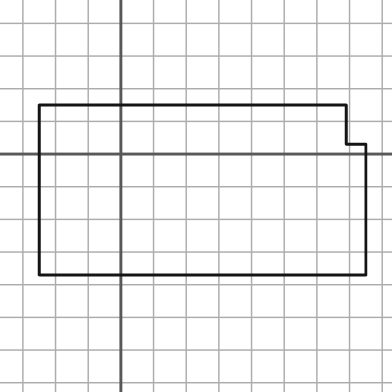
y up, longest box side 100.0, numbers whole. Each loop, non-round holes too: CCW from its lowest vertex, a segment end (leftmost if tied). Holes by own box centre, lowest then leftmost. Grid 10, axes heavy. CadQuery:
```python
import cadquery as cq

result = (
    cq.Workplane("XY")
    .moveTo(-25.0, -37.0)
    .lineTo(75.0, -37.0)
    .lineTo(75.0, 3.0)
    .lineTo(69.0, 3.0)
    .lineTo(69.0, 15.0)
    .lineTo(-25.0, 15.0)
    .close()
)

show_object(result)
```